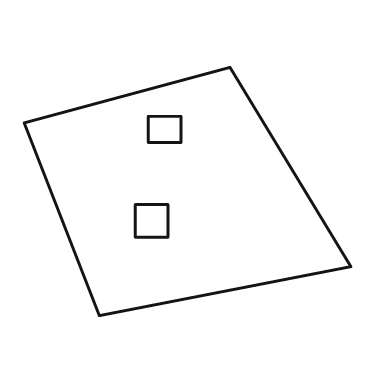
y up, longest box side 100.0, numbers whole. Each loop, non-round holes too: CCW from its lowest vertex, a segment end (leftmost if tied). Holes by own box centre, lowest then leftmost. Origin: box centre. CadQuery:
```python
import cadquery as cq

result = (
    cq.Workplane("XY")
    .moveTo(-27.0, -38.0)
    .lineTo(50.0, -23.0)
    .lineTo(13.0, 38.0)
    .lineTo(-50.0, 21.0)
    .close()
    .moveTo(-16.0, -14.0)
    .lineTo(-6.0, -14.0)
    .lineTo(-6.0, -4.0)
    .lineTo(-16.0, -4.0)
    .close()
    .moveTo(-12.0, 15.0)
    .lineTo(-2.0, 15.0)
    .lineTo(-2.0, 23.0)
    .lineTo(-12.0, 23.0)
    .close()
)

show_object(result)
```